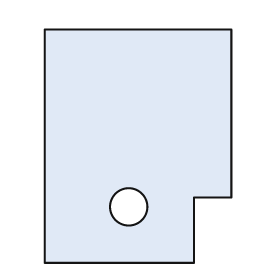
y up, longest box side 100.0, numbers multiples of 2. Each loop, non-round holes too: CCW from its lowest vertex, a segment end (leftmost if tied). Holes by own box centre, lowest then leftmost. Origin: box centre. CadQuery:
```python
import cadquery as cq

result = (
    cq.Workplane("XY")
    .moveTo(-40.0, -50.0)
    .lineTo(24.0, -50.0)
    .lineTo(24.0, -22.0)
    .lineTo(40.0, -22.0)
    .lineTo(40.0, 50.0)
    .lineTo(-40.0, 50.0)
    .close()
    .moveTo(-4.0, -26.0)
    .circle(8.0)
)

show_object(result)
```